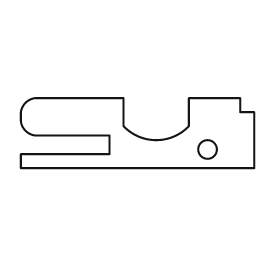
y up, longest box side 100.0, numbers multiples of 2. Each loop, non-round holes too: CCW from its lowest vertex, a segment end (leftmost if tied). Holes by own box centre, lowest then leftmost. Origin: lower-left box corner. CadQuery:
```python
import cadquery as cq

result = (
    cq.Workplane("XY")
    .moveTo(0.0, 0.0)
    .lineTo(100.0, 0.0)
    .lineTo(100.0, 24.0)
    .lineTo(94.0, 24.0)
    .lineTo(94.0, 30.0)
    .lineTo(72.0, 30.0)
    .lineTo(72.0, 18.0)
    .threePointArc((58.0, 12.0), (44.0, 18.0))
    .lineTo(44.0, 30.0)
    .lineTo(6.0, 30.0)
    .threePointArc((2.0, 28.0), (0.0, 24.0))
    .lineTo(0.0, 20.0)
    .threePointArc((2.0, 16.0), (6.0, 14.0))
    .lineTo(38.0, 14.0)
    .lineTo(38.0, 6.0)
    .lineTo(0.0, 6.0)
    .close()
    .moveTo(80.0, 8.0)
    .circle(4.0)
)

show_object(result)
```